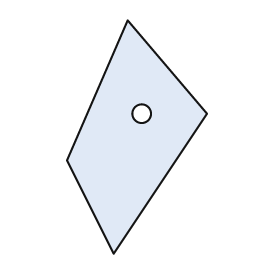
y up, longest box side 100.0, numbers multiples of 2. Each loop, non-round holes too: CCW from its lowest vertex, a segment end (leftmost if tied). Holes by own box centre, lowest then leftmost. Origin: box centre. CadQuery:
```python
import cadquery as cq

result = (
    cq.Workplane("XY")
    .moveTo(-10.0, -50.0)
    .lineTo(30.0, 10.0)
    .lineTo(-4.0, 50.0)
    .lineTo(-30.0, -10.0)
    .close()
    .moveTo(2.0, 10.0)
    .circle(4.0)
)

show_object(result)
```